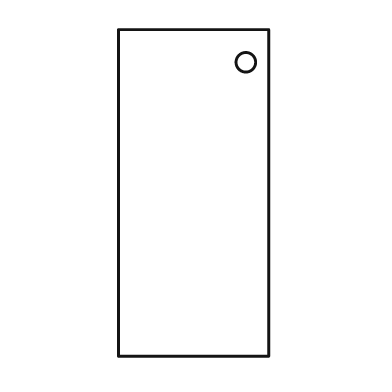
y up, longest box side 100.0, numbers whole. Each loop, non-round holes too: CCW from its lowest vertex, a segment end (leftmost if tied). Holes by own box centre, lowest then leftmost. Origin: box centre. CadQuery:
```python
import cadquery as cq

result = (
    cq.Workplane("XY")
    .moveTo(-23.0, -50.0)
    .lineTo(23.0, -50.0)
    .lineTo(23.0, 50.0)
    .lineTo(-23.0, 50.0)
    .close()
    .moveTo(16.0, 40.0)
    .circle(3.0)
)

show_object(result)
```